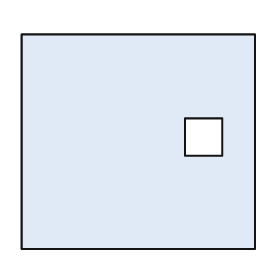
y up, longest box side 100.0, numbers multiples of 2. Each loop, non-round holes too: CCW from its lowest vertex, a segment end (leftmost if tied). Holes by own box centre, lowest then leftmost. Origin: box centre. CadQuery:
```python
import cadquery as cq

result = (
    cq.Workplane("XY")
    .moveTo(-50.0, -46.0)
    .lineTo(50.0, -46.0)
    .lineTo(50.0, 46.0)
    .lineTo(-50.0, 46.0)
    .close()
    .moveTo(20.0, -6.0)
    .lineTo(36.0, -6.0)
    .lineTo(36.0, 10.0)
    .lineTo(20.0, 10.0)
    .close()
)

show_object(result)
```